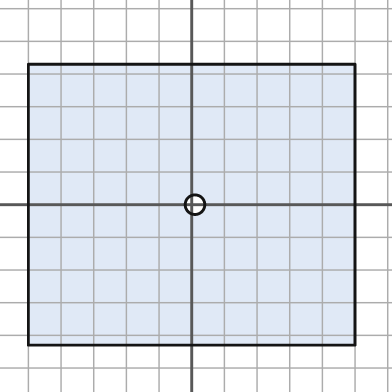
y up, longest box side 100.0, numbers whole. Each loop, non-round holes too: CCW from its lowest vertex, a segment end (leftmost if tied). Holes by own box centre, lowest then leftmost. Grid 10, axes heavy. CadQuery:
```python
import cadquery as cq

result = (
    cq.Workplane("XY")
    .moveTo(-50.0, -43.0)
    .lineTo(50.0, -43.0)
    .lineTo(50.0, 43.0)
    .lineTo(-50.0, 43.0)
    .close()
    .moveTo(1.0, 0.0)
    .circle(3.0)
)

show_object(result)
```